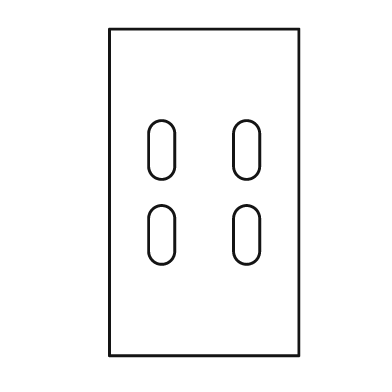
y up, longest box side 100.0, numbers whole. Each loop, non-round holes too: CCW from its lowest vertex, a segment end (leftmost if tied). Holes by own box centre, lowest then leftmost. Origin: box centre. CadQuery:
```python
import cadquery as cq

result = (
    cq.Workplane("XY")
    .moveTo(-29.0, -50.0)
    .lineTo(29.0, -50.0)
    .lineTo(29.0, 50.0)
    .lineTo(-29.0, 50.0)
    .close()
    .moveTo(-17.0, -18.0)
    .threePointArc((-13.0, -22.0), (-9.0, -18.0))
    .lineTo(-9.0, -8.0)
    .threePointArc((-13.0, -4.0), (-17.0, -8.0))
    .close()
    .moveTo(9.0, -18.0)
    .threePointArc((13.0, -22.0), (17.0, -18.0))
    .lineTo(17.0, -8.0)
    .threePointArc((13.0, -4.0), (9.0, -8.0))
    .close()
    .moveTo(-17.0, 8.0)
    .threePointArc((-13.0, 4.0), (-9.0, 8.0))
    .lineTo(-9.0, 18.0)
    .threePointArc((-13.0, 22.0), (-17.0, 18.0))
    .close()
    .moveTo(9.0, 8.0)
    .threePointArc((13.0, 4.0), (17.0, 8.0))
    .lineTo(17.0, 18.0)
    .threePointArc((13.0, 22.0), (9.0, 18.0))
    .close()
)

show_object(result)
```